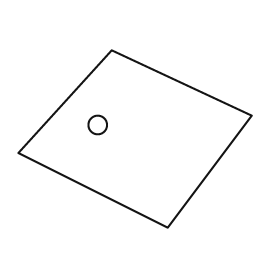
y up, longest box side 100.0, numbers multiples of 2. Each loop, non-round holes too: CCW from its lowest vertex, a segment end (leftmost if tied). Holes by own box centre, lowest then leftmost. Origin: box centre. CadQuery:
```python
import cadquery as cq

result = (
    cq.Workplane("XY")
    .moveTo(14.0, -38.0)
    .lineTo(50.0, 10.0)
    .lineTo(-10.0, 38.0)
    .lineTo(-50.0, -6.0)
    .close()
    .moveTo(-16.0, 6.0)
    .circle(4.0)
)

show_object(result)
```